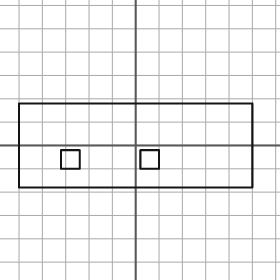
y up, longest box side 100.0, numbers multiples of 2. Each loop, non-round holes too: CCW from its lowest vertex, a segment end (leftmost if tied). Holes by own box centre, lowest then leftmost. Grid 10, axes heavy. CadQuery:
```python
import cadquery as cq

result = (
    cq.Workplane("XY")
    .moveTo(-50.0, -18.0)
    .lineTo(50.0, -18.0)
    .lineTo(50.0, 18.0)
    .lineTo(-50.0, 18.0)
    .close()
    .moveTo(-32.0, -10.0)
    .lineTo(-24.0, -10.0)
    .lineTo(-24.0, -2.0)
    .lineTo(-32.0, -2.0)
    .close()
    .moveTo(2.0, -10.0)
    .lineTo(10.0, -10.0)
    .lineTo(10.0, -2.0)
    .lineTo(2.0, -2.0)
    .close()
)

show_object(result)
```